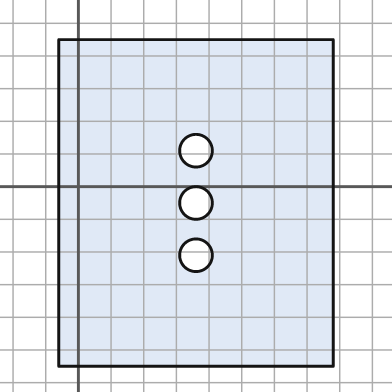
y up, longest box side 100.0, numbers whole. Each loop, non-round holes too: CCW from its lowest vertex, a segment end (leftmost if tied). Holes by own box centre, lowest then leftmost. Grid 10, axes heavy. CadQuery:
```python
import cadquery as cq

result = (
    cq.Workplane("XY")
    .moveTo(-6.0, -55.0)
    .lineTo(78.0, -55.0)
    .lineTo(78.0, 45.0)
    .lineTo(-6.0, 45.0)
    .close()
    .moveTo(36.0, -21.0)
    .circle(5.0)
    .moveTo(36.0, -5.0)
    .circle(5.0)
    .moveTo(36.0, 11.0)
    .circle(5.0)
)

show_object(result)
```